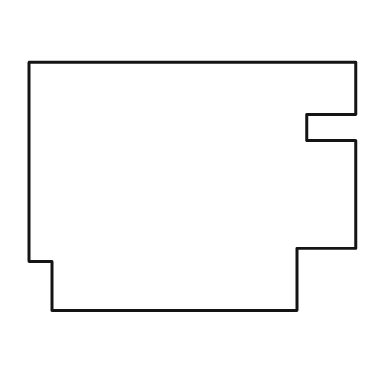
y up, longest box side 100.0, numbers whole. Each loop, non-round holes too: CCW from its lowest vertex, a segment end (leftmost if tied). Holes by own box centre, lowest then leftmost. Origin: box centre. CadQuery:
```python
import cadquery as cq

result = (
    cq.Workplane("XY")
    .moveTo(-43.0, -38.0)
    .lineTo(32.0, -38.0)
    .lineTo(32.0, -19.0)
    .lineTo(50.0, -19.0)
    .lineTo(50.0, 14.0)
    .lineTo(35.0, 14.0)
    .lineTo(35.0, 22.0)
    .lineTo(50.0, 22.0)
    .lineTo(50.0, 38.0)
    .lineTo(-50.0, 38.0)
    .lineTo(-50.0, -23.0)
    .lineTo(-43.0, -23.0)
    .close()
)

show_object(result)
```